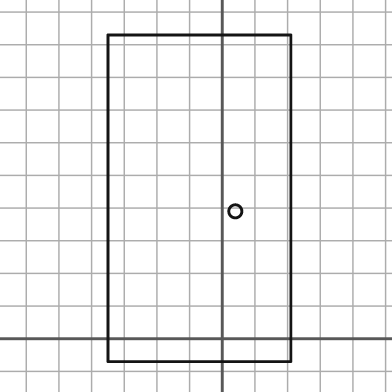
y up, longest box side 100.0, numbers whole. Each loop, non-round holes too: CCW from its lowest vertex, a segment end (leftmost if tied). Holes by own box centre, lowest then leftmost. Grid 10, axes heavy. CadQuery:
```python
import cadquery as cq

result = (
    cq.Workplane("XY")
    .moveTo(-35.0, -7.0)
    .lineTo(21.0, -7.0)
    .lineTo(21.0, 93.0)
    .lineTo(-35.0, 93.0)
    .close()
    .moveTo(4.0, 39.0)
    .circle(2.0)
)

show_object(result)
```